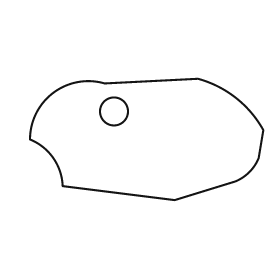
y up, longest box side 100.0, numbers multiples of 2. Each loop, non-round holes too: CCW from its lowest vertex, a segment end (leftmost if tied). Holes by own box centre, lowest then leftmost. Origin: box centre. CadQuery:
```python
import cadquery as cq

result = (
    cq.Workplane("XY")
    .moveTo(12.0, -26.0)
    .lineTo(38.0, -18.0)
    .threePointArc((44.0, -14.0), (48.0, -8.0))
    .lineTo(50.0, 4.0)
    .threePointArc((38.0, 18.0), (22.0, 26.0))
    .lineTo(-18.0, 24.0)
    .threePointArc((-40.0, 20.0), (-50.0, 0.0))
    .threePointArc((-40.0, -8.0), (-36.0, -20.0))
    .close()
    .moveTo(-14.0, 12.0)
    .circle(6.0)
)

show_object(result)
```